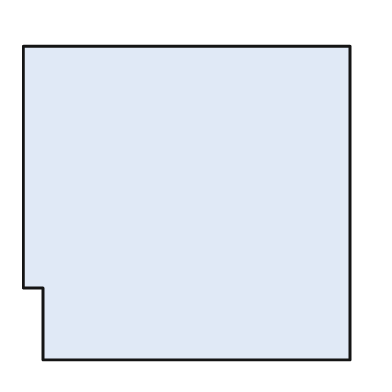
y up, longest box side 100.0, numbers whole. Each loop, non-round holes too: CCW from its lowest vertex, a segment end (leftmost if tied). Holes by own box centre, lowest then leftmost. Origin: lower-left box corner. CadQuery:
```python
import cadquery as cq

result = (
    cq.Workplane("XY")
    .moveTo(6.0, 0.0)
    .lineTo(100.0, 0.0)
    .lineTo(100.0, 96.0)
    .lineTo(0.0, 96.0)
    .lineTo(0.0, 22.0)
    .lineTo(6.0, 22.0)
    .close()
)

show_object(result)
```